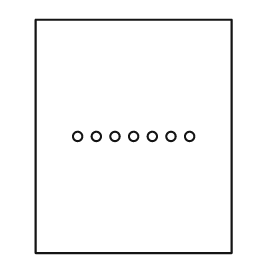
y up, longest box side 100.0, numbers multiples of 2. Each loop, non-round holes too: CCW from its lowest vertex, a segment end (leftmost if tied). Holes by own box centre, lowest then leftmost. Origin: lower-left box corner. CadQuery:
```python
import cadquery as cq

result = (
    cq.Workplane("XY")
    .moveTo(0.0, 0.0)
    .lineTo(84.0, 0.0)
    .lineTo(84.0, 100.0)
    .lineTo(0.0, 100.0)
    .close()
    .moveTo(18.0, 50.0)
    .circle(2.0)
    .moveTo(26.0, 50.0)
    .circle(2.0)
    .moveTo(34.0, 50.0)
    .circle(2.0)
    .moveTo(42.0, 50.0)
    .circle(2.0)
    .moveTo(50.0, 50.0)
    .circle(2.0)
    .moveTo(58.0, 50.0)
    .circle(2.0)
    .moveTo(66.0, 50.0)
    .circle(2.0)
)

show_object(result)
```